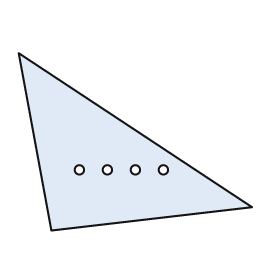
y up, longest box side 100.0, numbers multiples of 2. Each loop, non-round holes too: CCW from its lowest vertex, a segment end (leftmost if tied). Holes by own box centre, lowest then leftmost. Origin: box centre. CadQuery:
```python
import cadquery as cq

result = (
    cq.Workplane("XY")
    .moveTo(-36.0, -38.0)
    .lineTo(50.0, -28.0)
    .lineTo(-50.0, 38.0)
    .close()
    .moveTo(-24.0, -12.0)
    .circle(2.0)
    .moveTo(-12.0, -12.0)
    .circle(2.0)
    .moveTo(0.0, -12.0)
    .circle(2.0)
    .moveTo(12.0, -12.0)
    .circle(2.0)
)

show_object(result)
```